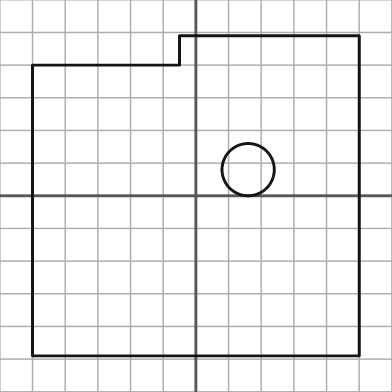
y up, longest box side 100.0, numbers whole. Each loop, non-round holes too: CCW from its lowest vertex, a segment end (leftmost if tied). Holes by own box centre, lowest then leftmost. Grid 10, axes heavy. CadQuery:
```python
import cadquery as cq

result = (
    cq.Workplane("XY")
    .moveTo(-50.0, -49.0)
    .lineTo(50.0, -49.0)
    .lineTo(50.0, 49.0)
    .lineTo(-5.0, 49.0)
    .lineTo(-5.0, 40.0)
    .lineTo(-50.0, 40.0)
    .close()
    .moveTo(16.0, 8.0)
    .circle(8.0)
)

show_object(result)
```